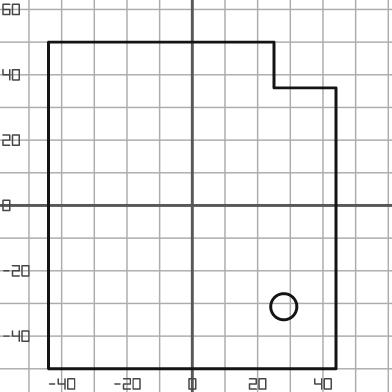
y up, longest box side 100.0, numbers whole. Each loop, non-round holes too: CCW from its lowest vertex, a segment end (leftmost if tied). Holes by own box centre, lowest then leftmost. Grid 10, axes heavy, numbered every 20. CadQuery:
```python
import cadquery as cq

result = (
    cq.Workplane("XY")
    .moveTo(-44.0, -50.0)
    .lineTo(44.0, -50.0)
    .lineTo(44.0, 36.0)
    .lineTo(25.0, 36.0)
    .lineTo(25.0, 50.0)
    .lineTo(-44.0, 50.0)
    .close()
    .moveTo(28.0, -31.0)
    .circle(4.0)
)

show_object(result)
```